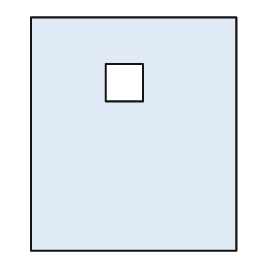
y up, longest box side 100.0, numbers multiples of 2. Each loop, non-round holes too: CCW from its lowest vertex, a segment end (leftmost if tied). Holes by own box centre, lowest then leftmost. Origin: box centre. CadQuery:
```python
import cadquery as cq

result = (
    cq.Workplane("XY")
    .moveTo(-44.0, -50.0)
    .lineTo(44.0, -50.0)
    .lineTo(44.0, 50.0)
    .lineTo(-44.0, 50.0)
    .close()
    .moveTo(-12.0, 14.0)
    .lineTo(4.0, 14.0)
    .lineTo(4.0, 30.0)
    .lineTo(-12.0, 30.0)
    .close()
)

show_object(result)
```